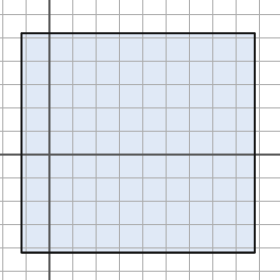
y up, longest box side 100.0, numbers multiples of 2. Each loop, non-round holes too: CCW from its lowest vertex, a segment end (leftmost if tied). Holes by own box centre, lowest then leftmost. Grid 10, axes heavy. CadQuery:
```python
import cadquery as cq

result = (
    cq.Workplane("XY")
    .moveTo(-12.0, -42.0)
    .lineTo(88.0, -42.0)
    .lineTo(88.0, 52.0)
    .lineTo(-12.0, 52.0)
    .close()
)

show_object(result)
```